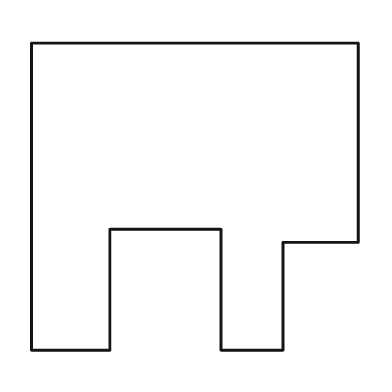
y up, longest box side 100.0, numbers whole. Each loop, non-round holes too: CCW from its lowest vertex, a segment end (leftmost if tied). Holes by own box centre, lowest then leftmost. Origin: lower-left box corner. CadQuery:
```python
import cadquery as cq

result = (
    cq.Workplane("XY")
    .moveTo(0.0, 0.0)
    .lineTo(24.0, 0.0)
    .lineTo(24.0, 37.0)
    .lineTo(58.0, 37.0)
    .lineTo(58.0, 0.0)
    .lineTo(77.0, 0.0)
    .lineTo(77.0, 33.0)
    .lineTo(100.0, 33.0)
    .lineTo(100.0, 94.0)
    .lineTo(0.0, 94.0)
    .close()
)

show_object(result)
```